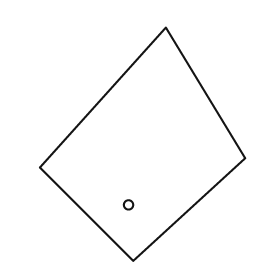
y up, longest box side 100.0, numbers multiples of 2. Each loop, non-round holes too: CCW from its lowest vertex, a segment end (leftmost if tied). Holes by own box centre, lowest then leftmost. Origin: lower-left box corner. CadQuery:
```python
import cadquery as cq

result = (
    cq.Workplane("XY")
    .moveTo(40.0, 0.0)
    .lineTo(88.0, 44.0)
    .lineTo(54.0, 100.0)
    .lineTo(0.0, 40.0)
    .close()
    .moveTo(38.0, 24.0)
    .circle(2.0)
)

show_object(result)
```